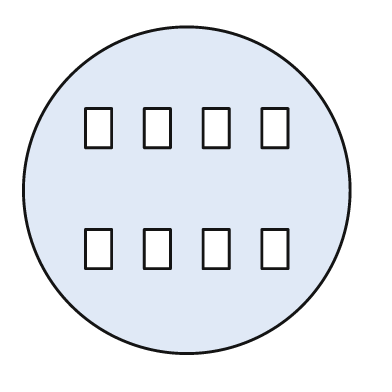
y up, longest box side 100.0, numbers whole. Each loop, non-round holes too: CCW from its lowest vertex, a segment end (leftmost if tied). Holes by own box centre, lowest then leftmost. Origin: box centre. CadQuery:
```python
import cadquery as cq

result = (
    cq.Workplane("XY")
    .moveTo(0.0, 0.0)
    .circle(50.0)
    .moveTo(-31.0, -24.0)
    .lineTo(-23.0, -24.0)
    .lineTo(-23.0, -12.0)
    .lineTo(-31.0, -12.0)
    .close()
    .moveTo(-13.0, -24.0)
    .lineTo(-5.0, -24.0)
    .lineTo(-5.0, -12.0)
    .lineTo(-13.0, -12.0)
    .close()
    .moveTo(5.0, -24.0)
    .lineTo(13.0, -24.0)
    .lineTo(13.0, -12.0)
    .lineTo(5.0, -12.0)
    .close()
    .moveTo(23.0, -24.0)
    .lineTo(31.0, -24.0)
    .lineTo(31.0, -12.0)
    .lineTo(23.0, -12.0)
    .close()
    .moveTo(-31.0, 13.0)
    .lineTo(-23.0, 13.0)
    .lineTo(-23.0, 25.0)
    .lineTo(-31.0, 25.0)
    .close()
    .moveTo(-13.0, 13.0)
    .lineTo(-5.0, 13.0)
    .lineTo(-5.0, 25.0)
    .lineTo(-13.0, 25.0)
    .close()
    .moveTo(5.0, 13.0)
    .lineTo(13.0, 13.0)
    .lineTo(13.0, 25.0)
    .lineTo(5.0, 25.0)
    .close()
    .moveTo(23.0, 13.0)
    .lineTo(31.0, 13.0)
    .lineTo(31.0, 25.0)
    .lineTo(23.0, 25.0)
    .close()
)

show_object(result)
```